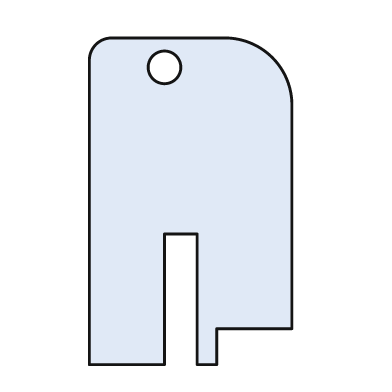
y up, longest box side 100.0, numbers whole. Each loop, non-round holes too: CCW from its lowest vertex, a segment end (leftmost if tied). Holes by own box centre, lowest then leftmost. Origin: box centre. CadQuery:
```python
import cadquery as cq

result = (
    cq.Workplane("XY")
    .moveTo(-31.0, -50.0)
    .lineTo(-8.0, -50.0)
    .lineTo(-8.0, -10.0)
    .lineTo(2.0, -10.0)
    .lineTo(2.0, -50.0)
    .lineTo(8.0, -50.0)
    .lineTo(8.0, -39.0)
    .lineTo(31.0, -39.0)
    .lineTo(31.0, 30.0)
    .threePointArc((25.0, 44.0), (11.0, 50.0))
    .lineTo(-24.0, 50.0)
    .threePointArc((-29.0, 48.0), (-31.0, 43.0))
    .close()
    .moveTo(-8.0, 41.0)
    .circle(5.0)
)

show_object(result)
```